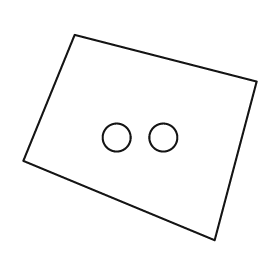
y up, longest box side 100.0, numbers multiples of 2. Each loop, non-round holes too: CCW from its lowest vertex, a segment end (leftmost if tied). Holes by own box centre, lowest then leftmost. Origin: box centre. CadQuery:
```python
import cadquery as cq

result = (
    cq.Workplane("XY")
    .moveTo(32.0, -44.0)
    .lineTo(50.0, 24.0)
    .lineTo(-28.0, 44.0)
    .lineTo(-50.0, -10.0)
    .close()
    .moveTo(-10.0, 0.0)
    .circle(6.0)
    .moveTo(10.0, 0.0)
    .circle(6.0)
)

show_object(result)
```